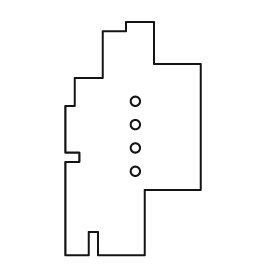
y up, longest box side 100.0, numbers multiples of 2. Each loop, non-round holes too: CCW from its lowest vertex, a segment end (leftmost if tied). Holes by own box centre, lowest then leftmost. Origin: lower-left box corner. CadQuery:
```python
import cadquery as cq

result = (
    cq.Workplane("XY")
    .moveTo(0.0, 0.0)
    .lineTo(10.0, 0.0)
    .lineTo(10.0, 10.0)
    .lineTo(14.0, 10.0)
    .lineTo(14.0, 0.0)
    .lineTo(34.0, 0.0)
    .lineTo(34.0, 28.0)
    .lineTo(58.0, 28.0)
    .lineTo(58.0, 82.0)
    .lineTo(38.0, 82.0)
    .lineTo(38.0, 100.0)
    .lineTo(26.0, 100.0)
    .lineTo(26.0, 96.0)
    .lineTo(16.0, 96.0)
    .lineTo(16.0, 76.0)
    .lineTo(4.0, 76.0)
    .lineTo(4.0, 64.0)
    .lineTo(0.0, 64.0)
    .lineTo(0.0, 44.0)
    .lineTo(6.0, 44.0)
    .lineTo(6.0, 40.0)
    .lineTo(0.0, 40.0)
    .close()
    .moveTo(30.0, 36.0)
    .circle(2.0)
    .moveTo(30.0, 46.0)
    .circle(2.0)
    .moveTo(30.0, 56.0)
    .circle(2.0)
    .moveTo(30.0, 66.0)
    .circle(2.0)
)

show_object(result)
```